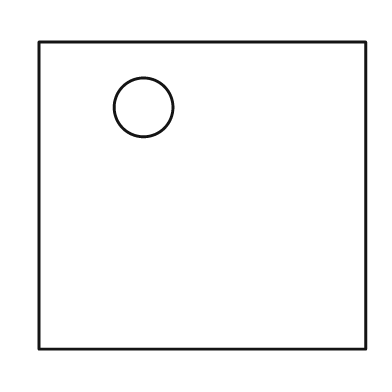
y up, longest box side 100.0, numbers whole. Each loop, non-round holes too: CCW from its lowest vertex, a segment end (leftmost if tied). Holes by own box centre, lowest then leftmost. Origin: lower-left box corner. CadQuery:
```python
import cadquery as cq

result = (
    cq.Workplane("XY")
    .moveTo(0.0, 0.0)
    .lineTo(100.0, 0.0)
    .lineTo(100.0, 94.0)
    .lineTo(0.0, 94.0)
    .close()
    .moveTo(32.0, 74.0)
    .circle(9.0)
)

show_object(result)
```